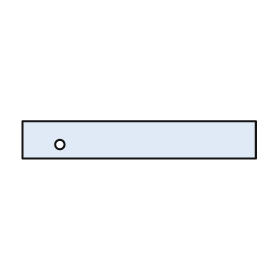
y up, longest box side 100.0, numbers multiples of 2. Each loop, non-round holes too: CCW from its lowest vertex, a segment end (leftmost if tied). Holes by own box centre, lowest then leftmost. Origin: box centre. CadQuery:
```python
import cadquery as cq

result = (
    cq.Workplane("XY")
    .moveTo(-50.0, -8.0)
    .lineTo(50.0, -8.0)
    .lineTo(50.0, 8.0)
    .lineTo(-50.0, 8.0)
    .close()
    .moveTo(-34.0, -2.0)
    .circle(2.0)
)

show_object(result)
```